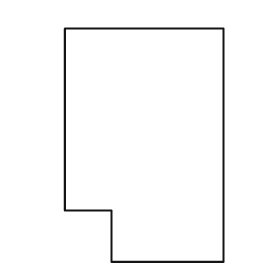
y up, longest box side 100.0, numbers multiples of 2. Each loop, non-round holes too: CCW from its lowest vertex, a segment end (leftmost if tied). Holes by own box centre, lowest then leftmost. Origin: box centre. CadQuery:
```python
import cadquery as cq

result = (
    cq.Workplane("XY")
    .moveTo(-14.0, -50.0)
    .lineTo(34.0, -50.0)
    .lineTo(34.0, 50.0)
    .lineTo(-34.0, 50.0)
    .lineTo(-34.0, -28.0)
    .lineTo(-14.0, -28.0)
    .close()
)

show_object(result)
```